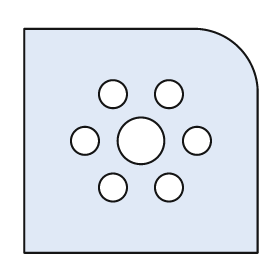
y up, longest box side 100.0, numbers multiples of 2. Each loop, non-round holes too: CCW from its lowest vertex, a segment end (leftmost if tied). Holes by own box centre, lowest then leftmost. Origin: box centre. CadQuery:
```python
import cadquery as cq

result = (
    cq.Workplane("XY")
    .moveTo(-50.0, -48.0)
    .lineTo(50.0, -48.0)
    .lineTo(50.0, 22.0)
    .threePointArc((42.0, 40.0), (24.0, 48.0))
    .lineTo(-50.0, 48.0)
    .close()
    .moveTo(-12.0, -20.0)
    .circle(6.0)
    .moveTo(12.0, -20.0)
    .circle(6.0)
    .moveTo(-24.0, 0.0)
    .circle(6.0)
    .moveTo(0.0, 0.0)
    .circle(10.0)
    .moveTo(24.0, 0.0)
    .circle(6.0)
    .moveTo(-12.0, 20.0)
    .circle(6.0)
    .moveTo(12.0, 20.0)
    .circle(6.0)
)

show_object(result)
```